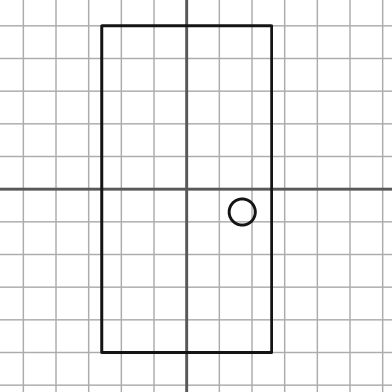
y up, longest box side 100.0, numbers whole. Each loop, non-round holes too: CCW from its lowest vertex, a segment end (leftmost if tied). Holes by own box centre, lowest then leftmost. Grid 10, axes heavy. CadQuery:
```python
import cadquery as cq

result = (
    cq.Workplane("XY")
    .moveTo(-26.0, -50.0)
    .lineTo(26.0, -50.0)
    .lineTo(26.0, 50.0)
    .lineTo(-26.0, 50.0)
    .close()
    .moveTo(17.0, -7.0)
    .circle(4.0)
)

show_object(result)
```